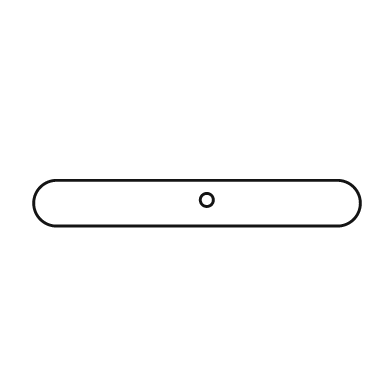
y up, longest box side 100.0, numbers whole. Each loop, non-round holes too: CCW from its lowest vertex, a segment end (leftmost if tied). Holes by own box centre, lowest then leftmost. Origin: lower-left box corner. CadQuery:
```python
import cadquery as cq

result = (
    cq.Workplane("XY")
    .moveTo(7.0, 0.0)
    .lineTo(93.0, 0.0)
    .threePointArc((100.0, 7.0), (93.0, 14.0))
    .lineTo(7.0, 14.0)
    .threePointArc((0.0, 7.0), (7.0, 0.0))
    .close()
    .moveTo(53.0, 8.0)
    .circle(2.0)
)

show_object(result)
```